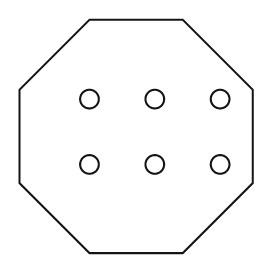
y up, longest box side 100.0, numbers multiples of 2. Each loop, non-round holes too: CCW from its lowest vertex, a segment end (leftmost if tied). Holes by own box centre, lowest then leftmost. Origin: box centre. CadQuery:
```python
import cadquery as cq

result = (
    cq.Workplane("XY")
    .moveTo(-20.0, -50.0)
    .lineTo(20.0, -50.0)
    .lineTo(50.0, -20.0)
    .lineTo(50.0, 20.0)
    .lineTo(20.0, 50.0)
    .lineTo(-20.0, 50.0)
    .lineTo(-50.0, 20.0)
    .lineTo(-50.0, -20.0)
    .close()
    .moveTo(-20.0, -12.0)
    .circle(4.0)
    .moveTo(8.0, -12.0)
    .circle(4.0)
    .moveTo(36.0, -12.0)
    .circle(4.0)
    .moveTo(-20.0, 16.0)
    .circle(4.0)
    .moveTo(8.0, 16.0)
    .circle(4.0)
    .moveTo(36.0, 16.0)
    .circle(4.0)
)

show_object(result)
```